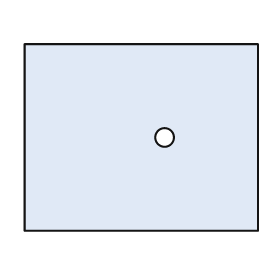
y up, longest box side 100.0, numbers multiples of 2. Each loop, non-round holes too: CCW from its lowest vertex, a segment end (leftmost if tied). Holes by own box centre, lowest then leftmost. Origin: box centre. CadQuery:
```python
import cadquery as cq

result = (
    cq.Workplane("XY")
    .moveTo(-50.0, -40.0)
    .lineTo(50.0, -40.0)
    .lineTo(50.0, 40.0)
    .lineTo(-50.0, 40.0)
    .close()
    .moveTo(10.0, 0.0)
    .circle(4.0)
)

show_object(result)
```